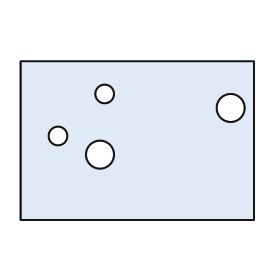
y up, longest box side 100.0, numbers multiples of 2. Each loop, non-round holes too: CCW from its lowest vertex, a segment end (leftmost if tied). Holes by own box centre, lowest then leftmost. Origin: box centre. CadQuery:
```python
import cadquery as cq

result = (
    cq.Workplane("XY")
    .moveTo(-50.0, -34.0)
    .lineTo(50.0, -34.0)
    .lineTo(50.0, 34.0)
    .lineTo(-50.0, 34.0)
    .close()
    .moveTo(-16.0, -6.0)
    .circle(6.0)
    .moveTo(-34.0, 2.0)
    .circle(4.0)
    .moveTo(40.0, 14.0)
    .circle(6.0)
    .moveTo(-14.0, 20.0)
    .circle(4.0)
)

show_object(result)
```